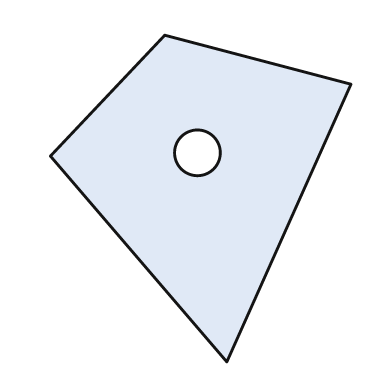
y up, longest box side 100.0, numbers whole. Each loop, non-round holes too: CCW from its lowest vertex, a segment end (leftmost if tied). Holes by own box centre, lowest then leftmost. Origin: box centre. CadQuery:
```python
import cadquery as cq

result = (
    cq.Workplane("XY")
    .moveTo(8.0, -50.0)
    .lineTo(46.0, 35.0)
    .lineTo(-11.0, 50.0)
    .lineTo(-46.0, 13.0)
    .close()
    .moveTo(-1.0, 14.0)
    .circle(7.0)
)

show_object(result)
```